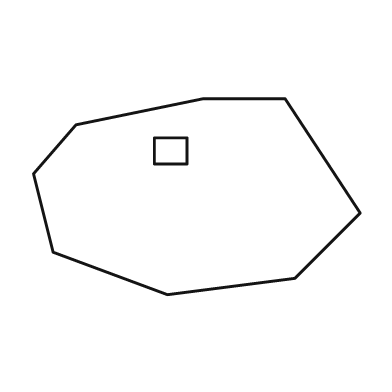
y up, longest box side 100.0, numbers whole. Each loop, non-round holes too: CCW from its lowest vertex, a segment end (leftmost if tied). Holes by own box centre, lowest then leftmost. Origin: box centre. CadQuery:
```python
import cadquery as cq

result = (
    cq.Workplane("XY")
    .moveTo(-9.0, -30.0)
    .lineTo(30.0, -25.0)
    .lineTo(50.0, -5.0)
    .lineTo(27.0, 30.0)
    .lineTo(2.0, 30.0)
    .lineTo(-37.0, 22.0)
    .lineTo(-50.0, 7.0)
    .lineTo(-44.0, -17.0)
    .close()
    .moveTo(-13.0, 10.0)
    .lineTo(-3.0, 10.0)
    .lineTo(-3.0, 18.0)
    .lineTo(-13.0, 18.0)
    .close()
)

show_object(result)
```